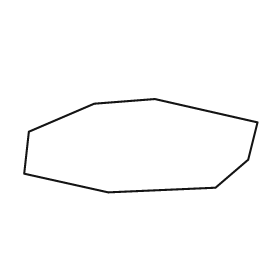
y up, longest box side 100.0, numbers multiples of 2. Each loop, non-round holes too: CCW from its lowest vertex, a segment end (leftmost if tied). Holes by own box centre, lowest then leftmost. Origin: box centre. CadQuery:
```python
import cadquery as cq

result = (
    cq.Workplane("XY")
    .moveTo(-14.0, -20.0)
    .lineTo(32.0, -18.0)
    .lineTo(46.0, -6.0)
    .lineTo(50.0, 10.0)
    .lineTo(6.0, 20.0)
    .lineTo(-20.0, 18.0)
    .lineTo(-48.0, 6.0)
    .lineTo(-50.0, -12.0)
    .close()
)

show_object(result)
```